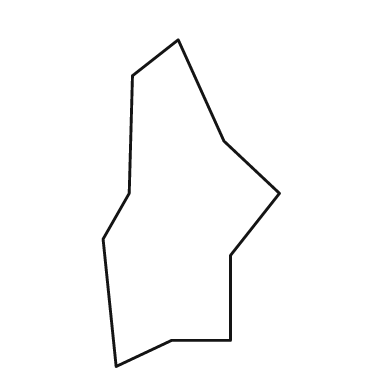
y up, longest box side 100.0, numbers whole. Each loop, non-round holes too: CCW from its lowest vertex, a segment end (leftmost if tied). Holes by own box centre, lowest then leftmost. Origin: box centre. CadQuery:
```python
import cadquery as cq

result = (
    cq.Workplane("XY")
    .moveTo(-23.0, -50.0)
    .lineTo(-6.0, -42.0)
    .lineTo(12.0, -42.0)
    .lineTo(12.0, -16.0)
    .lineTo(27.0, 3.0)
    .lineTo(10.0, 19.0)
    .lineTo(-4.0, 50.0)
    .lineTo(-18.0, 39.0)
    .lineTo(-19.0, 3.0)
    .lineTo(-27.0, -11.0)
    .close()
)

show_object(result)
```